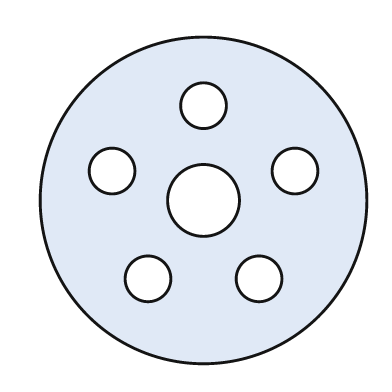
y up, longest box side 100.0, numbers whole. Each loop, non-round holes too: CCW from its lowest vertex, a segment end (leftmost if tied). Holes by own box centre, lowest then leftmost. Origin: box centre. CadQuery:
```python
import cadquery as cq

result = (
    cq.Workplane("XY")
    .moveTo(0.0, 0.0)
    .circle(50.0)
    .moveTo(-17.0, -24.0)
    .circle(7.0)
    .moveTo(17.0, -24.0)
    .circle(7.0)
    .moveTo(0.0, 0.0)
    .circle(11.0)
    .moveTo(-28.0, 9.0)
    .circle(7.0)
    .moveTo(28.0, 9.0)
    .circle(7.0)
    .moveTo(0.0, 29.0)
    .circle(7.0)
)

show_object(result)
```